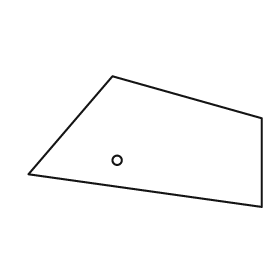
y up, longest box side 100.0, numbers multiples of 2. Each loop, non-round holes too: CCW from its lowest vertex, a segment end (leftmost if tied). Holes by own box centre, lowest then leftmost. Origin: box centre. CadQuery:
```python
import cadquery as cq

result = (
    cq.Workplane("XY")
    .moveTo(50.0, -28.0)
    .lineTo(50.0, 10.0)
    .lineTo(-14.0, 28.0)
    .lineTo(-50.0, -14.0)
    .close()
    .moveTo(-12.0, -8.0)
    .circle(2.0)
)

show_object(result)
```